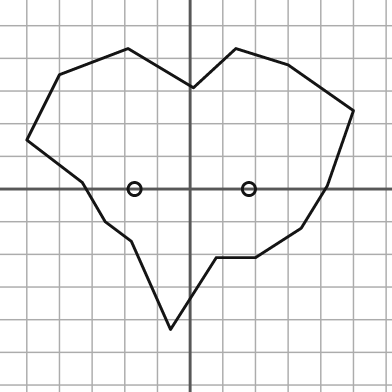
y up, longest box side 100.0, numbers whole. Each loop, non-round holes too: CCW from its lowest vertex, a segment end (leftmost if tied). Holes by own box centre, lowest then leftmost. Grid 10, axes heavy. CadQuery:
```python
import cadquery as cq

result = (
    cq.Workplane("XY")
    .moveTo(-6.0, -43.0)
    .lineTo(8.0, -21.0)
    .lineTo(20.0, -21.0)
    .lineTo(34.0, -12.0)
    .lineTo(42.0, 1.0)
    .lineTo(50.0, 24.0)
    .lineTo(30.0, 38.0)
    .lineTo(14.0, 43.0)
    .lineTo(1.0, 31.0)
    .lineTo(-19.0, 43.0)
    .lineTo(-40.0, 35.0)
    .lineTo(-50.0, 15.0)
    .lineTo(-33.0, 2.0)
    .lineTo(-26.0, -10.0)
    .lineTo(-18.0, -16.0)
    .close()
    .moveTo(-17.0, 0.0)
    .circle(2.0)
    .moveTo(18.0, 0.0)
    .circle(2.0)
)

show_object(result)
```